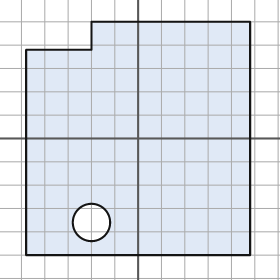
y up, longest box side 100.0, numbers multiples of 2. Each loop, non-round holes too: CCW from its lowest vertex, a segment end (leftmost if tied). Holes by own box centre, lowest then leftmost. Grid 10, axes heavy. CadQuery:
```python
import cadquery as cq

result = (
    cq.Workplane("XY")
    .moveTo(-48.0, -50.0)
    .lineTo(48.0, -50.0)
    .lineTo(48.0, 50.0)
    .lineTo(-20.0, 50.0)
    .lineTo(-20.0, 38.0)
    .lineTo(-48.0, 38.0)
    .close()
    .moveTo(-20.0, -36.0)
    .circle(8.0)
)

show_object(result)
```